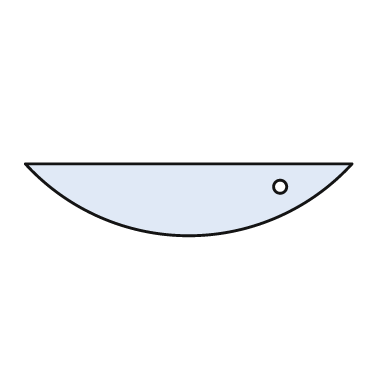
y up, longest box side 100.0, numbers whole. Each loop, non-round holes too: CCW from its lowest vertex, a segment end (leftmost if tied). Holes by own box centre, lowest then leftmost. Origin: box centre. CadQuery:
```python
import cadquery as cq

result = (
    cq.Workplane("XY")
    .moveTo(-50.0, 11.0)
    .threePointArc((0.0, -11.0), (50.0, 11.0))
    .close()
    .moveTo(28.0, 4.0)
    .circle(2.0)
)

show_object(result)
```